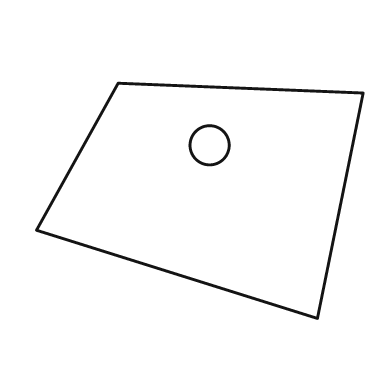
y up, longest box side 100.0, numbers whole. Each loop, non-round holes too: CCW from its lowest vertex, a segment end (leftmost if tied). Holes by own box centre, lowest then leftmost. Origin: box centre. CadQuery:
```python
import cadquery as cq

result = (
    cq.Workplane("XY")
    .moveTo(36.0, -36.0)
    .lineTo(50.0, 33.0)
    .lineTo(-25.0, 36.0)
    .lineTo(-50.0, -9.0)
    .close()
    .moveTo(3.0, 17.0)
    .circle(6.0)
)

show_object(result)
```